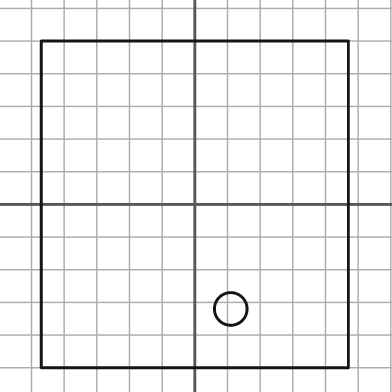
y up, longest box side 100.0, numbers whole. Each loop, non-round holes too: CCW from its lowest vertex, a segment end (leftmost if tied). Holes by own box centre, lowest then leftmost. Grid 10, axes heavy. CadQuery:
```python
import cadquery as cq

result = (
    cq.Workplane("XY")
    .moveTo(-47.0, -50.0)
    .lineTo(47.0, -50.0)
    .lineTo(47.0, 50.0)
    .lineTo(-47.0, 50.0)
    .close()
    .moveTo(11.0, -32.0)
    .circle(5.0)
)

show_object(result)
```